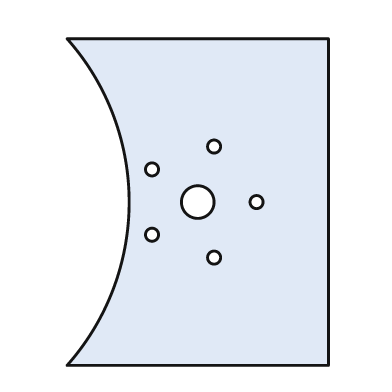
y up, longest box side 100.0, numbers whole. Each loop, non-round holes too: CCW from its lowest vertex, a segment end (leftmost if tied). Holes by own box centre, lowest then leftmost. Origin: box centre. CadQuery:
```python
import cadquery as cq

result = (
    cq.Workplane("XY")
    .moveTo(-40.0, -50.0)
    .lineTo(40.0, -50.0)
    .lineTo(40.0, 50.0)
    .lineTo(-40.0, 50.0)
    .threePointArc((-21.0, 0.0), (-40.0, -50.0))
    .close()
    .moveTo(5.0, -17.0)
    .circle(2.0)
    .moveTo(-14.0, -10.0)
    .circle(2.0)
    .moveTo(0.0, 0.0)
    .circle(5.0)
    .moveTo(18.0, 0.0)
    .circle(2.0)
    .moveTo(-14.0, 10.0)
    .circle(2.0)
    .moveTo(5.0, 17.0)
    .circle(2.0)
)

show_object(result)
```